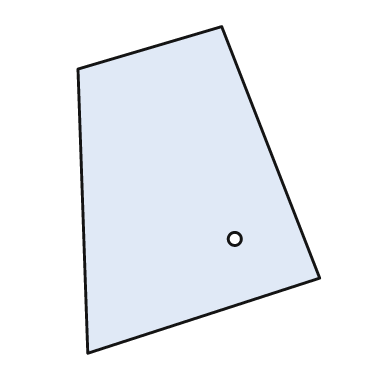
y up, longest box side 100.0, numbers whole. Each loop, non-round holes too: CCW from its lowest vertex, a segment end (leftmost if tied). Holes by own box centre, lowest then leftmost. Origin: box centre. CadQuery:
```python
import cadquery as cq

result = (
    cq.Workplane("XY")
    .moveTo(-34.0, -50.0)
    .lineTo(37.0, -27.0)
    .lineTo(7.0, 50.0)
    .lineTo(-37.0, 37.0)
    .close()
    .moveTo(11.0, -15.0)
    .circle(2.0)
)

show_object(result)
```